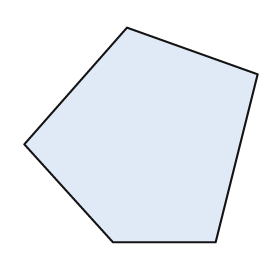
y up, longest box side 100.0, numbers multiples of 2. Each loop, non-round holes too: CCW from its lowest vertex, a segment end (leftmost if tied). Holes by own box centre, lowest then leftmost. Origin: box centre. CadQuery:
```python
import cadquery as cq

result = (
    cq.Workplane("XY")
    .moveTo(-12.0, -46.0)
    .lineTo(32.0, -46.0)
    .lineTo(50.0, 26.0)
    .lineTo(-6.0, 46.0)
    .lineTo(-50.0, -4.0)
    .close()
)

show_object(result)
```